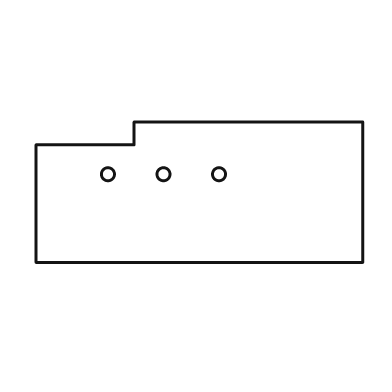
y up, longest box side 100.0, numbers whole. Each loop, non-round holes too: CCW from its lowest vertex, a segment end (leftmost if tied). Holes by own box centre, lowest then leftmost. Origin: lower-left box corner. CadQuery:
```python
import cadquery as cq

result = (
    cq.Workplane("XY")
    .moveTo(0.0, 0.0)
    .lineTo(100.0, 0.0)
    .lineTo(100.0, 43.0)
    .lineTo(30.0, 43.0)
    .lineTo(30.0, 36.0)
    .lineTo(0.0, 36.0)
    .close()
    .moveTo(22.0, 27.0)
    .circle(2.0)
    .moveTo(39.0, 27.0)
    .circle(2.0)
    .moveTo(56.0, 27.0)
    .circle(2.0)
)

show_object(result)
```